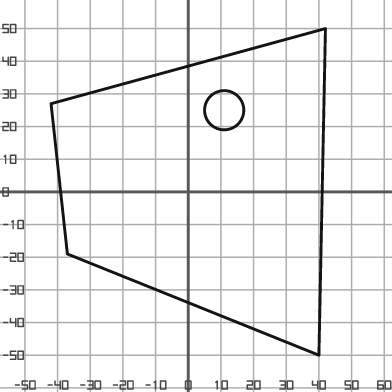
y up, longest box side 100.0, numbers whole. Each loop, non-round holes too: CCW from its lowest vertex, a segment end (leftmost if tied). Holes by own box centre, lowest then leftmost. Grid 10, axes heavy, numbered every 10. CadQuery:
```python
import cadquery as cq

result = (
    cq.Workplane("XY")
    .moveTo(40.0, -50.0)
    .lineTo(42.0, 50.0)
    .lineTo(-42.0, 27.0)
    .lineTo(-37.0, -19.0)
    .close()
    .moveTo(11.0, 25.0)
    .circle(6.0)
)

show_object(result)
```